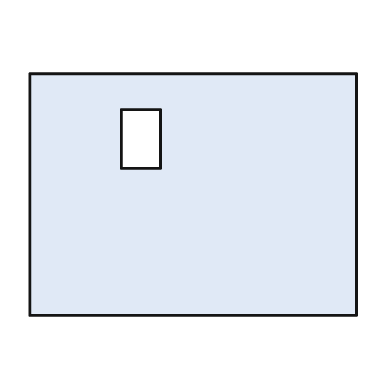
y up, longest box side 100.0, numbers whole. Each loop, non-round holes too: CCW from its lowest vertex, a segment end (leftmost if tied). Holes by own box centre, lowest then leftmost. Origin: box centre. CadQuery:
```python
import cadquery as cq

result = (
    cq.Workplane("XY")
    .moveTo(-50.0, -37.0)
    .lineTo(50.0, -37.0)
    .lineTo(50.0, 37.0)
    .lineTo(-50.0, 37.0)
    .close()
    .moveTo(-22.0, 8.0)
    .lineTo(-10.0, 8.0)
    .lineTo(-10.0, 26.0)
    .lineTo(-22.0, 26.0)
    .close()
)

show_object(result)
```